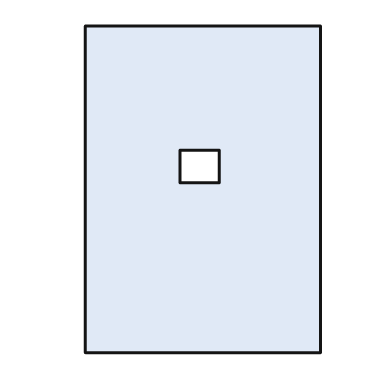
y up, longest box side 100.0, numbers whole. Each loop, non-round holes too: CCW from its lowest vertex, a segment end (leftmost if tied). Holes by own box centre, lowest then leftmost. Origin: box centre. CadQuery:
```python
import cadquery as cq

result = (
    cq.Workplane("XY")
    .moveTo(-36.0, -50.0)
    .lineTo(36.0, -50.0)
    .lineTo(36.0, 50.0)
    .lineTo(-36.0, 50.0)
    .close()
    .moveTo(-7.0, 2.0)
    .lineTo(5.0, 2.0)
    .lineTo(5.0, 12.0)
    .lineTo(-7.0, 12.0)
    .close()
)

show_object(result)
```